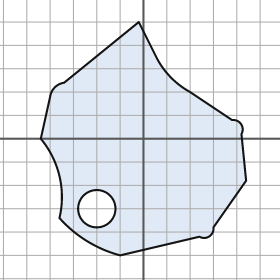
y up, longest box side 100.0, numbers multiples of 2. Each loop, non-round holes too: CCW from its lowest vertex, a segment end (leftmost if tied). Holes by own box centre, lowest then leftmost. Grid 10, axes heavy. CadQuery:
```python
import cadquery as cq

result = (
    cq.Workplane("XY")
    .moveTo(-10.0, -50.0)
    .lineTo(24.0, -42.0)
    .threePointArc((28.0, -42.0), (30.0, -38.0))
    .lineTo(44.0, -18.0)
    .lineTo(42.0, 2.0)
    .threePointArc((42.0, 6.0), (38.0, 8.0))
    .lineTo(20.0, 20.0)
    .threePointArc((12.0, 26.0), (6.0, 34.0))
    .lineTo(-2.0, 50.0)
    .lineTo(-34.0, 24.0)
    .threePointArc((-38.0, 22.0), (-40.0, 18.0))
    .lineTo(-44.0, 0.0)
    .threePointArc((-36.0, -16.0), (-36.0, -34.0))
    .threePointArc((-24.0, -44.0), (-10.0, -50.0))
    .close()
    .moveTo(-20.0, -30.0)
    .circle(8.0)
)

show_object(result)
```